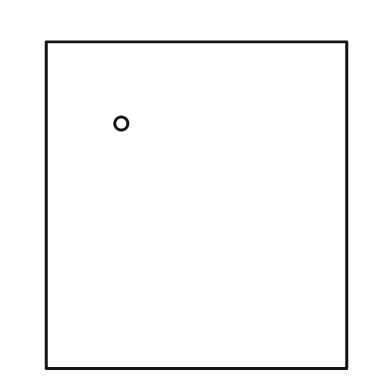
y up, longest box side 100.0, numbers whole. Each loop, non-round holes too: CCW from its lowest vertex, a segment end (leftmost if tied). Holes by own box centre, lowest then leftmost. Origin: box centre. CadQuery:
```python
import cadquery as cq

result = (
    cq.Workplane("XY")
    .moveTo(-46.0, -50.0)
    .lineTo(46.0, -50.0)
    .lineTo(46.0, 50.0)
    .lineTo(-46.0, 50.0)
    .close()
    .moveTo(-23.0, 25.0)
    .circle(2.0)
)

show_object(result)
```